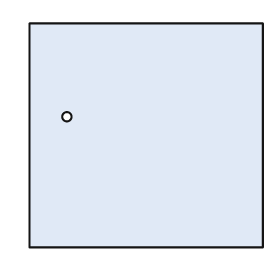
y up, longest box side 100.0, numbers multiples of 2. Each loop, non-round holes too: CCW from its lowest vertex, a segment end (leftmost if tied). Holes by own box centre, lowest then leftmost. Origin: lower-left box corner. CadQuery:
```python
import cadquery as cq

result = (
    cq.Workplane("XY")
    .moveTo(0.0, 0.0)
    .lineTo(100.0, 0.0)
    .lineTo(100.0, 96.0)
    .lineTo(0.0, 96.0)
    .close()
    .moveTo(16.0, 56.0)
    .circle(2.0)
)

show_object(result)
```